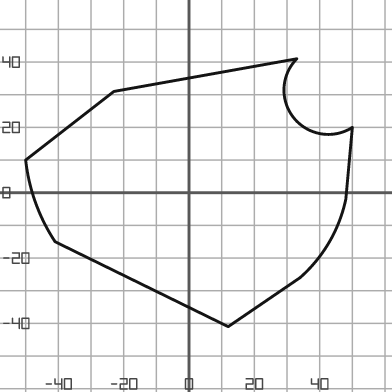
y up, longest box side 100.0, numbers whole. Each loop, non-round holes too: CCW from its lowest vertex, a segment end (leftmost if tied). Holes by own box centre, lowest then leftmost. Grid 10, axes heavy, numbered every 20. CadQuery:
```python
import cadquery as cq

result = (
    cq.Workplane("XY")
    .moveTo(12.0, -41.0)
    .lineTo(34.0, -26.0)
    .threePointArc((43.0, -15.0), (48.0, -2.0))
    .lineTo(50.0, 20.0)
    .threePointArc((32.0, 23.0), (33.0, 41.0))
    .lineTo(-23.0, 31.0)
    .lineTo(-50.0, 10.0)
    .threePointArc((-47.0, -3.0), (-41.0, -15.0))
    .close()
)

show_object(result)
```